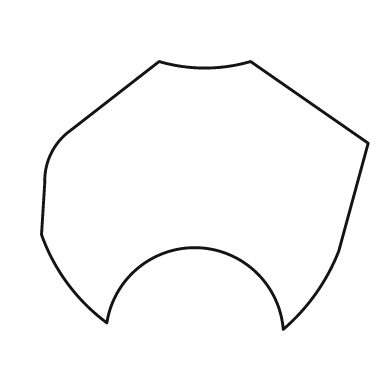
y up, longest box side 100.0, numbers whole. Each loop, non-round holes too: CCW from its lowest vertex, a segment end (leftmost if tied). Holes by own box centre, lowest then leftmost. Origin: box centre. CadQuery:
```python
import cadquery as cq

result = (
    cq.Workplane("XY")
    .moveTo(24.0, -41.0)
    .threePointArc((34.0, -30.0), (41.0, -17.0))
    .lineTo(50.0, 16.0)
    .lineTo(14.0, 41.0)
    .threePointArc((0.0, 39.0), (-14.0, 41.0))
    .lineTo(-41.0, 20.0)
    .threePointArc((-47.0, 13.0), (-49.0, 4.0))
    .lineTo(-50.0, -12.0)
    .threePointArc((-42.0, -27.0), (-30.0, -39.0))
    .threePointArc((-2.0, -16.0), (24.0, -41.0))
    .close()
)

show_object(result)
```